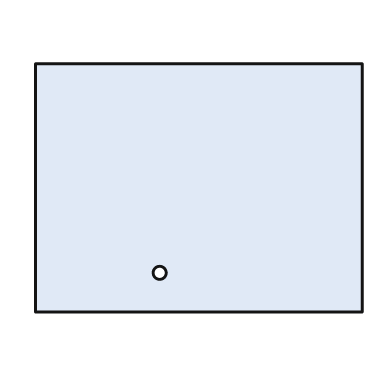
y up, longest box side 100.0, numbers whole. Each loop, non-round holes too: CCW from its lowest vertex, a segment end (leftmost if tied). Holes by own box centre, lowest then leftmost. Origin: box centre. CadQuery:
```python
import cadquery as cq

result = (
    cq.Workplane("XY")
    .moveTo(-50.0, -38.0)
    .lineTo(50.0, -38.0)
    .lineTo(50.0, 38.0)
    .lineTo(-50.0, 38.0)
    .close()
    .moveTo(-12.0, -26.0)
    .circle(2.0)
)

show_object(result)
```